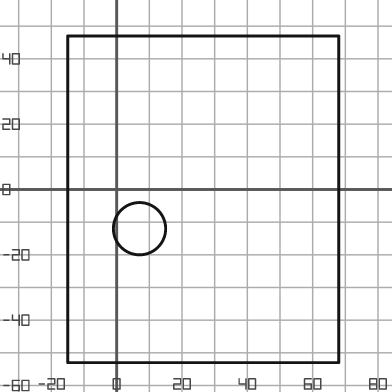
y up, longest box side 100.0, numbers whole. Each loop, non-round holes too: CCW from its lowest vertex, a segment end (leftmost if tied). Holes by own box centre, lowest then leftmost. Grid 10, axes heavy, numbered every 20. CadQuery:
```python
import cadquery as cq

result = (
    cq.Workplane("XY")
    .moveTo(-15.0, -53.0)
    .lineTo(68.0, -53.0)
    .lineTo(68.0, 47.0)
    .lineTo(-15.0, 47.0)
    .close()
    .moveTo(7.0, -12.0)
    .circle(8.0)
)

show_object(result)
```